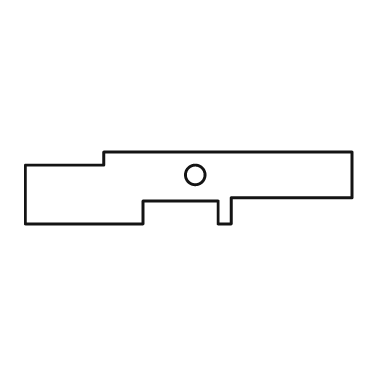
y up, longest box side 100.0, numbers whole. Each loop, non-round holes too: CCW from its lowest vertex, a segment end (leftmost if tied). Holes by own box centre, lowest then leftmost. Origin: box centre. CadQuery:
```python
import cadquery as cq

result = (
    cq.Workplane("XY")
    .moveTo(-50.0, -11.0)
    .lineTo(-14.0, -11.0)
    .lineTo(-14.0, -4.0)
    .lineTo(9.0, -4.0)
    .lineTo(9.0, -11.0)
    .lineTo(13.0, -11.0)
    .lineTo(13.0, -3.0)
    .lineTo(50.0, -3.0)
    .lineTo(50.0, 11.0)
    .lineTo(-26.0, 11.0)
    .lineTo(-26.0, 7.0)
    .lineTo(-50.0, 7.0)
    .close()
    .moveTo(2.0, 4.0)
    .circle(3.0)
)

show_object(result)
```